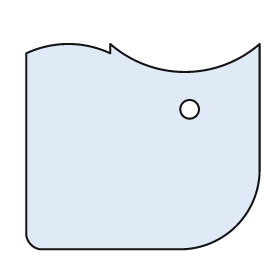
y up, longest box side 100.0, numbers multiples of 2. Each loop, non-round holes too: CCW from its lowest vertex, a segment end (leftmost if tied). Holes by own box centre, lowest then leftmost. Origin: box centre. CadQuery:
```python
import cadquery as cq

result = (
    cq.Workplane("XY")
    .moveTo(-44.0, -44.0)
    .lineTo(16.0, -44.0)
    .threePointArc((40.0, -34.0), (50.0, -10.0))
    .lineTo(50.0, 44.0)
    .threePointArc((18.0, 32.0), (-14.0, 44.0))
    .lineTo(-14.0, 40.0)
    .threePointArc((-32.0, 44.0), (-50.0, 40.0))
    .lineTo(-50.0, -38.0)
    .threePointArc((-48.0, -42.0), (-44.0, -44.0))
    .close()
    .moveTo(20.0, 16.0)
    .circle(4.0)
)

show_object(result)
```